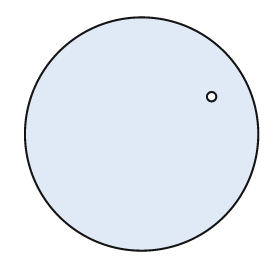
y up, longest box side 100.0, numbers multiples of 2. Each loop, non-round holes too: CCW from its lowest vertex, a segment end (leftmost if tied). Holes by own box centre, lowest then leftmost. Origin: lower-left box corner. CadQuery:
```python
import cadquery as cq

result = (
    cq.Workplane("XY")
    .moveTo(50.0, 50.0)
    .circle(50.0)
    .moveTo(80.0, 66.0)
    .circle(2.0)
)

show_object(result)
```